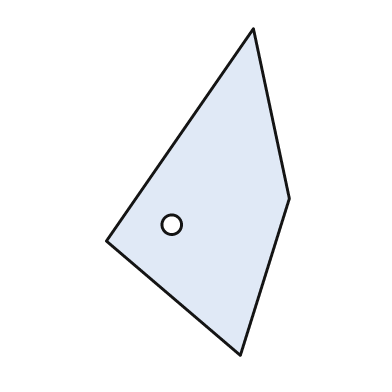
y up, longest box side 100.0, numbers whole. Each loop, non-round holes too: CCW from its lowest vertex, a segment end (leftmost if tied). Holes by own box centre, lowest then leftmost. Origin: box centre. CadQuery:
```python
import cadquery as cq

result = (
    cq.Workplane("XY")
    .moveTo(13.0, -50.0)
    .lineTo(28.0, -2.0)
    .lineTo(17.0, 50.0)
    .lineTo(-28.0, -15.0)
    .close()
    .moveTo(-8.0, -10.0)
    .circle(3.0)
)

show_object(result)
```